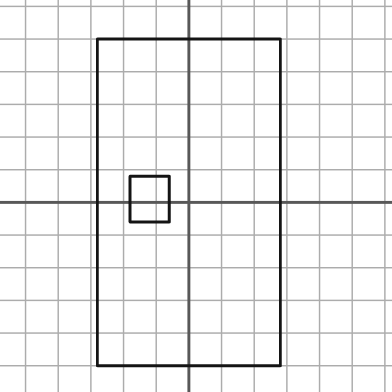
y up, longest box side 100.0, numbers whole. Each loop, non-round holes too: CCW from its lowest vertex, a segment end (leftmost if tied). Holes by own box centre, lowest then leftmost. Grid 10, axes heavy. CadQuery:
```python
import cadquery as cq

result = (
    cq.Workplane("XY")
    .moveTo(-28.0, -50.0)
    .lineTo(28.0, -50.0)
    .lineTo(28.0, 50.0)
    .lineTo(-28.0, 50.0)
    .close()
    .moveTo(-18.0, -6.0)
    .lineTo(-6.0, -6.0)
    .lineTo(-6.0, 8.0)
    .lineTo(-18.0, 8.0)
    .close()
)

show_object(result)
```